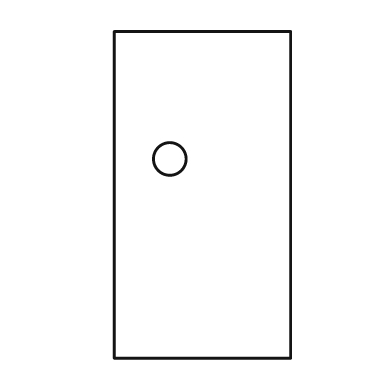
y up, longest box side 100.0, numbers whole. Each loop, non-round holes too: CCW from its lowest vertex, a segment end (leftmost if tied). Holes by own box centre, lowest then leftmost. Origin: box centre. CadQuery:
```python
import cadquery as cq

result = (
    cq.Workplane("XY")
    .moveTo(-27.0, -50.0)
    .lineTo(27.0, -50.0)
    .lineTo(27.0, 50.0)
    .lineTo(-27.0, 50.0)
    .close()
    .moveTo(-10.0, 11.0)
    .circle(5.0)
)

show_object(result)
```